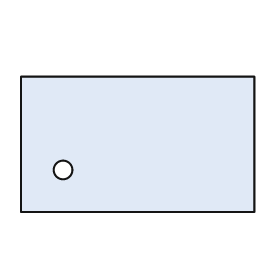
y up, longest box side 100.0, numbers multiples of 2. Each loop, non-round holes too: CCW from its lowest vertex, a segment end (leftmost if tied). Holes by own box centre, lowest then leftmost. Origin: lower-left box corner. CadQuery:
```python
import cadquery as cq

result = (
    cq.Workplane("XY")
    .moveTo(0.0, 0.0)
    .lineTo(100.0, 0.0)
    .lineTo(100.0, 58.0)
    .lineTo(0.0, 58.0)
    .close()
    .moveTo(18.0, 18.0)
    .circle(4.0)
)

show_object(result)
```